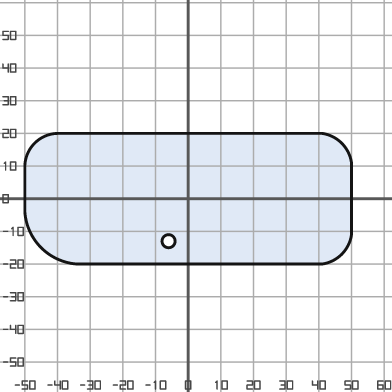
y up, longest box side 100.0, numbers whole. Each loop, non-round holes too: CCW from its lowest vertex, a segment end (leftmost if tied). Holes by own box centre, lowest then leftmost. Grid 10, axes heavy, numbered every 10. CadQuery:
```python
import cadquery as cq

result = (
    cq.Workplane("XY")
    .moveTo(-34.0, -20.0)
    .lineTo(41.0, -20.0)
    .threePointArc((47.0, -17.0), (50.0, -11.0))
    .lineTo(50.0, 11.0)
    .threePointArc((47.0, 17.0), (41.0, 20.0))
    .lineTo(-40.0, 20.0)
    .threePointArc((-47.0, 17.0), (-50.0, 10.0))
    .lineTo(-50.0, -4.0)
    .threePointArc((-45.0, -15.0), (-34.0, -20.0))
    .close()
    .moveTo(-6.0, -13.0)
    .circle(2.0)
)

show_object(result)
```